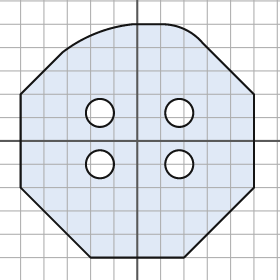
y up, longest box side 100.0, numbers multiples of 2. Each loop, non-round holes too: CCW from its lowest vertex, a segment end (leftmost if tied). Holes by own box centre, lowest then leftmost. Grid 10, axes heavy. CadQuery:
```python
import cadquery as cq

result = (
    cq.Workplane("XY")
    .moveTo(-20.0, -50.0)
    .lineTo(20.0, -50.0)
    .lineTo(50.0, -20.0)
    .lineTo(50.0, 20.0)
    .lineTo(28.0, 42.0)
    .threePointArc((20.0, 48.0), (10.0, 50.0))
    .lineTo(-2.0, 50.0)
    .threePointArc((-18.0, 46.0), (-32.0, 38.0))
    .lineTo(-50.0, 20.0)
    .lineTo(-50.0, -20.0)
    .close()
    .moveTo(-16.0, -10.0)
    .circle(6.0)
    .moveTo(18.0, -10.0)
    .circle(6.0)
    .moveTo(-16.0, 12.0)
    .circle(6.0)
    .moveTo(18.0, 12.0)
    .circle(6.0)
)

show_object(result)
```